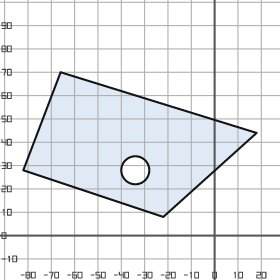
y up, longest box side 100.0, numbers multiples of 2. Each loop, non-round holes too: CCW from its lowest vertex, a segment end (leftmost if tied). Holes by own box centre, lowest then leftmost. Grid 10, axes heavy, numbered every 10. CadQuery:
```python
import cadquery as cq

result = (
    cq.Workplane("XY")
    .moveTo(-22.0, 8.0)
    .lineTo(18.0, 44.0)
    .lineTo(-66.0, 70.0)
    .lineTo(-82.0, 28.0)
    .close()
    .moveTo(-34.0, 28.0)
    .circle(6.0)
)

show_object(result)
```